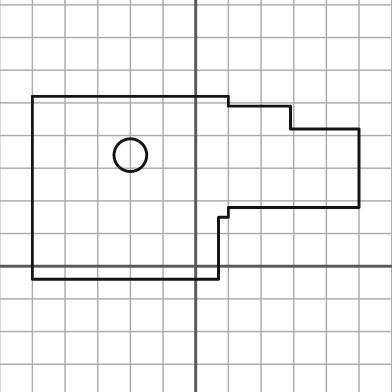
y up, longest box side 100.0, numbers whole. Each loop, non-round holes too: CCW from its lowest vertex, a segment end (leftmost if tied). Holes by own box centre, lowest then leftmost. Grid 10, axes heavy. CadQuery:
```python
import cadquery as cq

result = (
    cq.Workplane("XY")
    .moveTo(-50.0, -4.0)
    .lineTo(7.0, -4.0)
    .lineTo(7.0, 15.0)
    .lineTo(10.0, 15.0)
    .lineTo(10.0, 18.0)
    .lineTo(50.0, 18.0)
    .lineTo(50.0, 42.0)
    .lineTo(29.0, 42.0)
    .lineTo(29.0, 49.0)
    .lineTo(10.0, 49.0)
    .lineTo(10.0, 52.0)
    .lineTo(-50.0, 52.0)
    .close()
    .moveTo(-20.0, 34.0)
    .circle(5.0)
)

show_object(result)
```